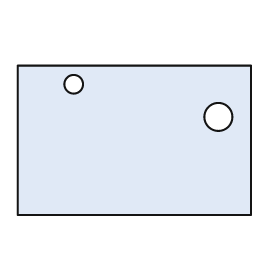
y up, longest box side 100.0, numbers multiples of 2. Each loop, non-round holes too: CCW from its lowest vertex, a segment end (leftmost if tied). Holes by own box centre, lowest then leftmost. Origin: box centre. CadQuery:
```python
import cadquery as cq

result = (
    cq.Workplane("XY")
    .moveTo(-50.0, -32.0)
    .lineTo(50.0, -32.0)
    .lineTo(50.0, 32.0)
    .lineTo(-50.0, 32.0)
    .close()
    .moveTo(36.0, 10.0)
    .circle(6.0)
    .moveTo(-26.0, 24.0)
    .circle(4.0)
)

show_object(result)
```